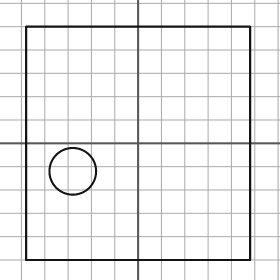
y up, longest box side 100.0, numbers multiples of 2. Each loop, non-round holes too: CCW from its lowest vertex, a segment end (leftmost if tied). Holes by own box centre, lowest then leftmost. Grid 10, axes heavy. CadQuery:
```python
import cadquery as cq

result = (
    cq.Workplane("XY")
    .moveTo(-48.0, -50.0)
    .lineTo(48.0, -50.0)
    .lineTo(48.0, 50.0)
    .lineTo(-48.0, 50.0)
    .close()
    .moveTo(-28.0, -12.0)
    .circle(10.0)
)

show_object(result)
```